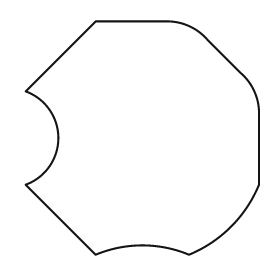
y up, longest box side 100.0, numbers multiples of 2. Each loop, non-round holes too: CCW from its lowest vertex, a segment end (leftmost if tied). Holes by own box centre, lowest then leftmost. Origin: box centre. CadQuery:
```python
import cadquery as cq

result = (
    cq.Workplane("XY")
    .moveTo(-20.0, -50.0)
    .threePointArc((0.0, -46.0), (20.0, -50.0))
    .threePointArc((38.0, -38.0), (50.0, -20.0))
    .lineTo(50.0, 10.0)
    .threePointArc((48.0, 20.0), (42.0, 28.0))
    .lineTo(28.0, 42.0)
    .threePointArc((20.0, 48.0), (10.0, 50.0))
    .lineTo(-20.0, 50.0)
    .lineTo(-50.0, 20.0)
    .threePointArc((-36.0, 0.0), (-50.0, -20.0))
    .close()
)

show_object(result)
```